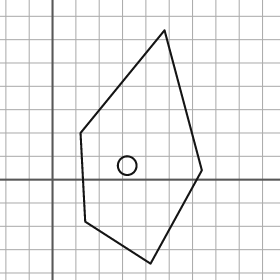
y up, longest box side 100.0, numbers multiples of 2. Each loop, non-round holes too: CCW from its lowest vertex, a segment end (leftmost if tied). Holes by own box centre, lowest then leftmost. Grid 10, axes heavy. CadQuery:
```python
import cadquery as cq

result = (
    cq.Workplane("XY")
    .moveTo(42.0, -36.0)
    .lineTo(64.0, 4.0)
    .lineTo(48.0, 64.0)
    .lineTo(12.0, 20.0)
    .lineTo(14.0, -18.0)
    .close()
    .moveTo(32.0, 6.0)
    .circle(4.0)
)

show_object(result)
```